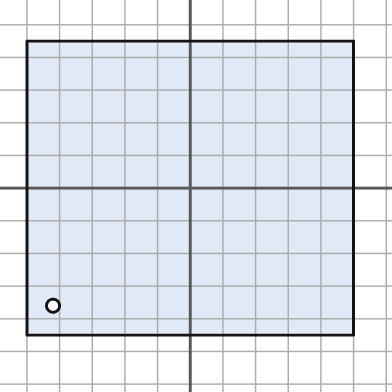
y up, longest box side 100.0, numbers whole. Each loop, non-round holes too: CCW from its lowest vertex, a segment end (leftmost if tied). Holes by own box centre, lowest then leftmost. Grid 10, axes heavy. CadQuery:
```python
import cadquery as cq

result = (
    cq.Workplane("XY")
    .moveTo(-50.0, -45.0)
    .lineTo(50.0, -45.0)
    .lineTo(50.0, 45.0)
    .lineTo(-50.0, 45.0)
    .close()
    .moveTo(-42.0, -36.0)
    .circle(2.0)
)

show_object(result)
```